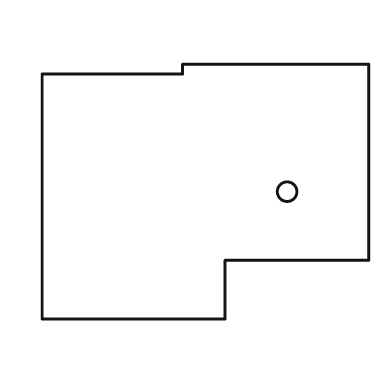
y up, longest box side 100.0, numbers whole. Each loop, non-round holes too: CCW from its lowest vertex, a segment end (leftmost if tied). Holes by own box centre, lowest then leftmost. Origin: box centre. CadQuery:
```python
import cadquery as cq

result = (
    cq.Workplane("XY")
    .moveTo(-50.0, -39.0)
    .lineTo(6.0, -39.0)
    .lineTo(6.0, -21.0)
    .lineTo(50.0, -21.0)
    .lineTo(50.0, 39.0)
    .lineTo(-7.0, 39.0)
    .lineTo(-7.0, 36.0)
    .lineTo(-50.0, 36.0)
    .close()
    .moveTo(25.0, 0.0)
    .circle(3.0)
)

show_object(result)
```